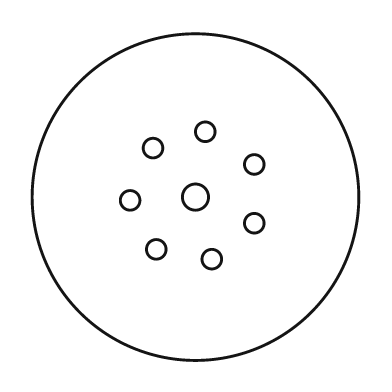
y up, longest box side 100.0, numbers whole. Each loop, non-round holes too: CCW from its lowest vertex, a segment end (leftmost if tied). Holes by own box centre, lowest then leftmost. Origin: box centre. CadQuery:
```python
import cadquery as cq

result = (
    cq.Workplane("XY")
    .moveTo(0.0, 0.0)
    .circle(50.0)
    .moveTo(5.0, -19.0)
    .circle(3.0)
    .moveTo(-12.0, -16.0)
    .circle(3.0)
    .moveTo(18.0, -8.0)
    .circle(3.0)
    .moveTo(-20.0, -1.0)
    .circle(3.0)
    .moveTo(0.0, 0.0)
    .circle(4.0)
    .moveTo(18.0, 10.0)
    .circle(3.0)
    .moveTo(-13.0, 15.0)
    .circle(3.0)
    .moveTo(3.0, 20.0)
    .circle(3.0)
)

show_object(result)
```